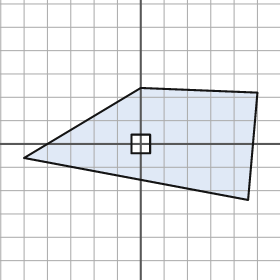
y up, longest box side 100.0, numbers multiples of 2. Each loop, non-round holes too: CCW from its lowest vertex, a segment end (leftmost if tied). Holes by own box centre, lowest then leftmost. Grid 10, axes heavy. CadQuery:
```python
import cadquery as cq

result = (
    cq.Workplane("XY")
    .moveTo(46.0, -24.0)
    .lineTo(50.0, 22.0)
    .lineTo(0.0, 24.0)
    .lineTo(-50.0, -6.0)
    .close()
    .moveTo(-4.0, -4.0)
    .lineTo(4.0, -4.0)
    .lineTo(4.0, 4.0)
    .lineTo(-4.0, 4.0)
    .close()
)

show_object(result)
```